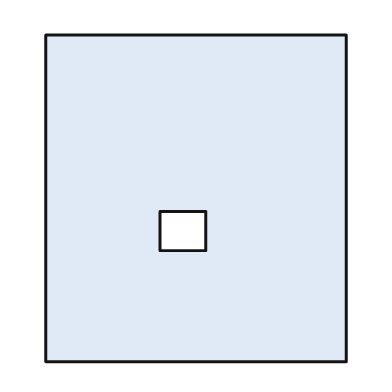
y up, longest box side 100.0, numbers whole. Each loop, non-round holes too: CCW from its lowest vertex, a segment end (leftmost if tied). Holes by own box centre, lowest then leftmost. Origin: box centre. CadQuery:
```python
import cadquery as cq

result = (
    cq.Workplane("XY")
    .moveTo(-46.0, -50.0)
    .lineTo(46.0, -50.0)
    .lineTo(46.0, 50.0)
    .lineTo(-46.0, 50.0)
    .close()
    .moveTo(-11.0, -16.0)
    .lineTo(3.0, -16.0)
    .lineTo(3.0, -4.0)
    .lineTo(-11.0, -4.0)
    .close()
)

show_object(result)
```